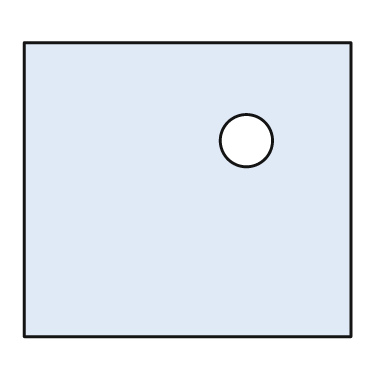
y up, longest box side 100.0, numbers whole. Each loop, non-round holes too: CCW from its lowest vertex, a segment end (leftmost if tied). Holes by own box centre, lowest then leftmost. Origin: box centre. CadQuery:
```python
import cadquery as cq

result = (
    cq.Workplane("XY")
    .moveTo(-50.0, -45.0)
    .lineTo(50.0, -45.0)
    .lineTo(50.0, 45.0)
    .lineTo(-50.0, 45.0)
    .close()
    .moveTo(18.0, 15.0)
    .circle(8.0)
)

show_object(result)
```